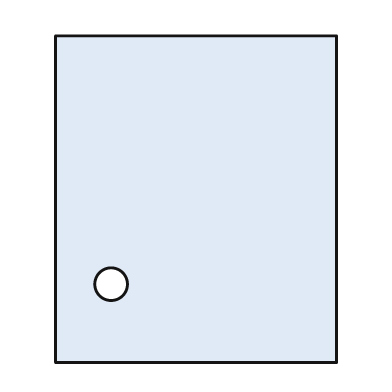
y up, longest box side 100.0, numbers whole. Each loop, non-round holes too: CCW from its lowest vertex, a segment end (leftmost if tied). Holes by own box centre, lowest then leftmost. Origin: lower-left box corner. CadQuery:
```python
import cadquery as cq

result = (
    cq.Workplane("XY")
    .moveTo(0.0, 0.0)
    .lineTo(86.0, 0.0)
    .lineTo(86.0, 100.0)
    .lineTo(0.0, 100.0)
    .close()
    .moveTo(17.0, 24.0)
    .circle(5.0)
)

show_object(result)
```